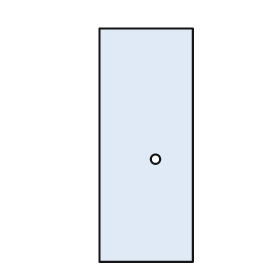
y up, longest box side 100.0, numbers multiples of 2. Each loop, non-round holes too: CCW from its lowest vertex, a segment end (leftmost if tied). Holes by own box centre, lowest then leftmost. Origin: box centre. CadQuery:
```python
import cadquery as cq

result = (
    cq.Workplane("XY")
    .moveTo(-20.0, -50.0)
    .lineTo(20.0, -50.0)
    .lineTo(20.0, 50.0)
    .lineTo(-20.0, 50.0)
    .close()
    .moveTo(4.0, -6.0)
    .circle(2.0)
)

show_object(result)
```